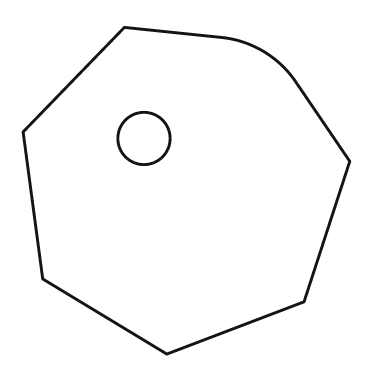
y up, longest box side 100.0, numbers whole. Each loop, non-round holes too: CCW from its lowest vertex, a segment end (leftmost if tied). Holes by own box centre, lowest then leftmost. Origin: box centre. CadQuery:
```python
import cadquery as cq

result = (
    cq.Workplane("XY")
    .moveTo(-6.0, -50.0)
    .lineTo(36.0, -34.0)
    .lineTo(50.0, 9.0)
    .lineTo(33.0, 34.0)
    .threePointArc((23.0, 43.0), (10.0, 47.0))
    .lineTo(-19.0, 50.0)
    .lineTo(-50.0, 18.0)
    .lineTo(-44.0, -27.0)
    .close()
    .moveTo(-13.0, 16.0)
    .circle(8.0)
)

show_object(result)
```